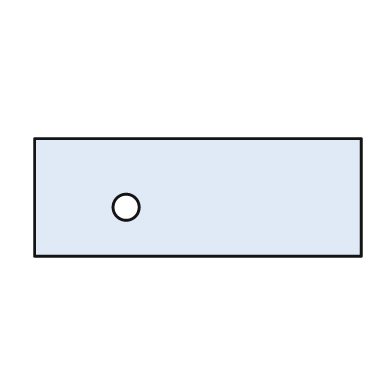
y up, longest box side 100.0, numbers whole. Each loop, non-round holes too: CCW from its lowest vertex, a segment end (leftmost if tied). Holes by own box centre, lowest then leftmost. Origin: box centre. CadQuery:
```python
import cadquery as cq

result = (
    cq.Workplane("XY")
    .moveTo(-50.0, -18.0)
    .lineTo(50.0, -18.0)
    .lineTo(50.0, 18.0)
    .lineTo(-50.0, 18.0)
    .close()
    .moveTo(-22.0, -3.0)
    .circle(4.0)
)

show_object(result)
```